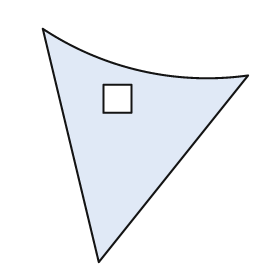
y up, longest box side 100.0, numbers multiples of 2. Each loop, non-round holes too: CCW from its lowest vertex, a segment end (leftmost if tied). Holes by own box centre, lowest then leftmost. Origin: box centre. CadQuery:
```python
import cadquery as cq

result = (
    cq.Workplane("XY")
    .moveTo(-20.0, -50.0)
    .lineTo(44.0, 30.0)
    .threePointArc((-2.0, 32.0), (-44.0, 50.0))
    .close()
    .moveTo(-18.0, 14.0)
    .lineTo(-6.0, 14.0)
    .lineTo(-6.0, 26.0)
    .lineTo(-18.0, 26.0)
    .close()
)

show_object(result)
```